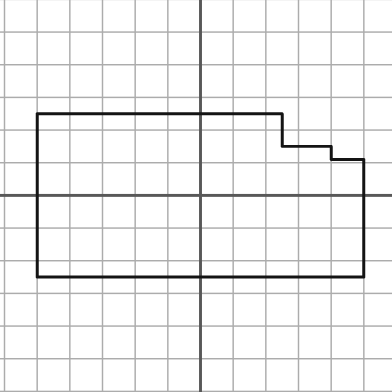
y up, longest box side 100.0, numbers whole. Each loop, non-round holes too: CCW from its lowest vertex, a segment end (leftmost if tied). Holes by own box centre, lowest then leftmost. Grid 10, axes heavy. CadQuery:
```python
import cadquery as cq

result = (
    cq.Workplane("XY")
    .moveTo(-50.0, -25.0)
    .lineTo(50.0, -25.0)
    .lineTo(50.0, 11.0)
    .lineTo(40.0, 11.0)
    .lineTo(40.0, 15.0)
    .lineTo(25.0, 15.0)
    .lineTo(25.0, 25.0)
    .lineTo(-50.0, 25.0)
    .close()
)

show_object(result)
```